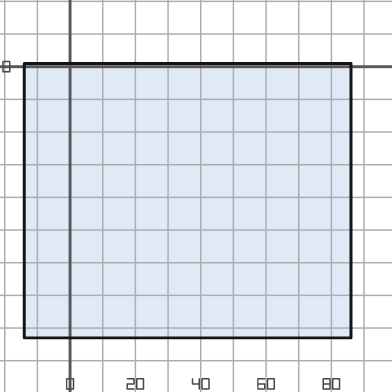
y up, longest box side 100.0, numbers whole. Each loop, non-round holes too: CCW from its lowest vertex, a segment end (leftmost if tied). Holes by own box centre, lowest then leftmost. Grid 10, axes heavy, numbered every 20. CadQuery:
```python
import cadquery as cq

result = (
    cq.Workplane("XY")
    .moveTo(-14.0, -83.0)
    .lineTo(86.0, -83.0)
    .lineTo(86.0, 1.0)
    .lineTo(-14.0, 1.0)
    .close()
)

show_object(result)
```